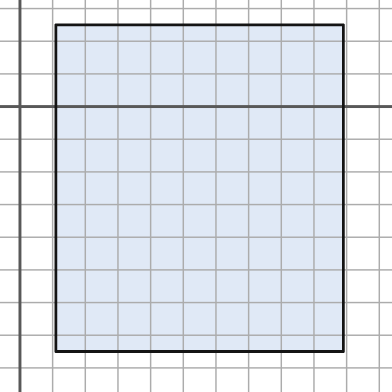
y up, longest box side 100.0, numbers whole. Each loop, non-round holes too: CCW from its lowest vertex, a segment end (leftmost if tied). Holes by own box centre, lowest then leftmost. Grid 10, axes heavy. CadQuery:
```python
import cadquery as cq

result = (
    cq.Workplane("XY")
    .moveTo(11.0, -75.0)
    .lineTo(99.0, -75.0)
    .lineTo(99.0, 25.0)
    .lineTo(11.0, 25.0)
    .close()
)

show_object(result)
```